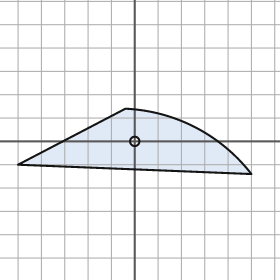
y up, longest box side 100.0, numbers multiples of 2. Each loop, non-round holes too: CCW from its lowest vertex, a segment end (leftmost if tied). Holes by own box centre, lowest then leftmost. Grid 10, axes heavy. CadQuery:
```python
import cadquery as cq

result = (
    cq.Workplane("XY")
    .moveTo(50.0, -14.0)
    .threePointArc((26.0, 6.0), (-4.0, 14.0))
    .lineTo(-50.0, -10.0)
    .close()
    .moveTo(0.0, 0.0)
    .circle(2.0)
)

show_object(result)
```